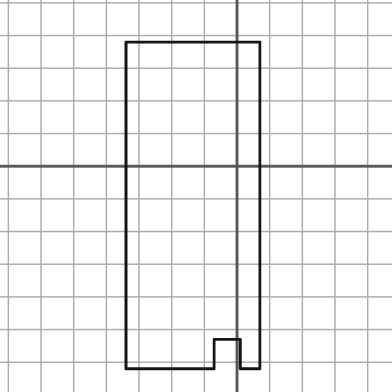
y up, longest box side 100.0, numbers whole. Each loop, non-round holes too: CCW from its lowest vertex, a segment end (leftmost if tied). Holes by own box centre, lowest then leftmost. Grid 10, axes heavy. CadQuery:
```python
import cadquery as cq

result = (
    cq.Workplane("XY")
    .moveTo(-34.0, -62.0)
    .lineTo(-7.0, -62.0)
    .lineTo(-7.0, -53.0)
    .lineTo(1.0, -53.0)
    .lineTo(1.0, -62.0)
    .lineTo(7.0, -62.0)
    .lineTo(7.0, 38.0)
    .lineTo(-34.0, 38.0)
    .close()
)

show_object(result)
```